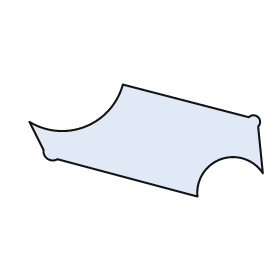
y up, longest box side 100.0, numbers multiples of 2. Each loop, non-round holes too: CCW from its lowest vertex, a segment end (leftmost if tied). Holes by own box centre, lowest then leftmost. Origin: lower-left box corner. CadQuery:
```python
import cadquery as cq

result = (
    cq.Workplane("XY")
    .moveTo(72.0, 0.0)
    .threePointArc((82.0, 16.0), (100.0, 10.0))
    .lineTo(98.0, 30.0)
    .threePointArc((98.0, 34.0), (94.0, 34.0))
    .lineTo(40.0, 48.0)
    .threePointArc((24.0, 30.0), (0.0, 32.0))
    .lineTo(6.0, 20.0)
    .threePointArc((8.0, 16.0), (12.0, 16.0))
    .close()
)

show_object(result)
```